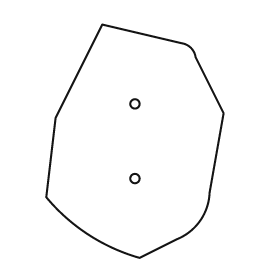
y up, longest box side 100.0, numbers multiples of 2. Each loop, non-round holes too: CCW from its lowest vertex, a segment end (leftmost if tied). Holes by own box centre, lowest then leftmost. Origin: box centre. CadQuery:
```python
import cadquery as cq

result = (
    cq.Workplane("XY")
    .moveTo(2.0, -50.0)
    .lineTo(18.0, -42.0)
    .threePointArc((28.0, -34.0), (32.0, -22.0))
    .lineTo(38.0, 12.0)
    .lineTo(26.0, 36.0)
    .threePointArc((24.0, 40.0), (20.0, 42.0))
    .lineTo(-14.0, 50.0)
    .lineTo(-34.0, 10.0)
    .lineTo(-38.0, -24.0)
    .threePointArc((-20.0, -40.0), (2.0, -50.0))
    .close()
    .moveTo(0.0, -16.0)
    .circle(2.0)
    .moveTo(0.0, 16.0)
    .circle(2.0)
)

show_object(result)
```